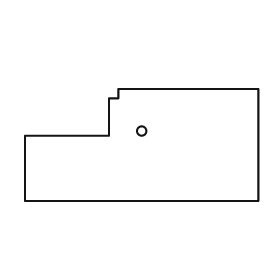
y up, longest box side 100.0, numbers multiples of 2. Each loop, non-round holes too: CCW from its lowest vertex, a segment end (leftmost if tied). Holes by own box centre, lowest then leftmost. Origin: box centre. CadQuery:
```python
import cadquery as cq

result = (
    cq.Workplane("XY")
    .moveTo(-50.0, -24.0)
    .lineTo(50.0, -24.0)
    .lineTo(50.0, 24.0)
    .lineTo(-10.0, 24.0)
    .lineTo(-10.0, 20.0)
    .lineTo(-14.0, 20.0)
    .lineTo(-14.0, 4.0)
    .lineTo(-50.0, 4.0)
    .close()
    .moveTo(0.0, 6.0)
    .circle(2.0)
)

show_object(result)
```